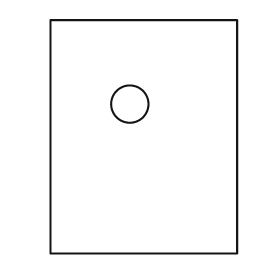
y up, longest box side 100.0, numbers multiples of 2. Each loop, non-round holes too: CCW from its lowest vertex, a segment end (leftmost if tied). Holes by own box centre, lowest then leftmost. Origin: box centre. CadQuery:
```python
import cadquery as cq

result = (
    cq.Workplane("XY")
    .moveTo(-40.0, -50.0)
    .lineTo(40.0, -50.0)
    .lineTo(40.0, 50.0)
    .lineTo(-40.0, 50.0)
    .close()
    .moveTo(-6.0, 14.0)
    .circle(8.0)
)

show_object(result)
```